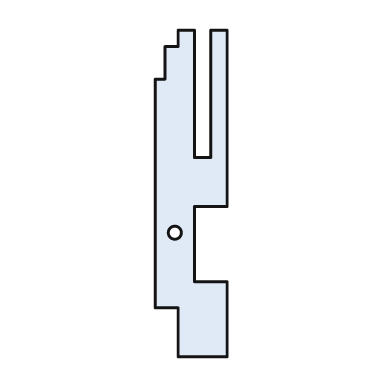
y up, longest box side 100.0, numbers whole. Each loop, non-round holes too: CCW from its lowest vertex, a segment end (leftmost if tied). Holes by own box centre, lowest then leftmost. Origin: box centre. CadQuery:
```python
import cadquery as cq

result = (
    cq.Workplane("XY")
    .moveTo(-4.0, -50.0)
    .lineTo(11.0, -50.0)
    .lineTo(11.0, -27.0)
    .lineTo(1.0, -27.0)
    .lineTo(1.0, -4.0)
    .lineTo(11.0, -4.0)
    .lineTo(11.0, 50.0)
    .lineTo(6.0, 50.0)
    .lineTo(6.0, 11.0)
    .lineTo(1.0, 11.0)
    .lineTo(1.0, 50.0)
    .lineTo(-4.0, 50.0)
    .lineTo(-4.0, 45.0)
    .lineTo(-8.0, 45.0)
    .lineTo(-8.0, 35.0)
    .lineTo(-11.0, 35.0)
    .lineTo(-11.0, -35.0)
    .lineTo(-4.0, -35.0)
    .close()
    .moveTo(-5.0, -12.0)
    .circle(2.0)
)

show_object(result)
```